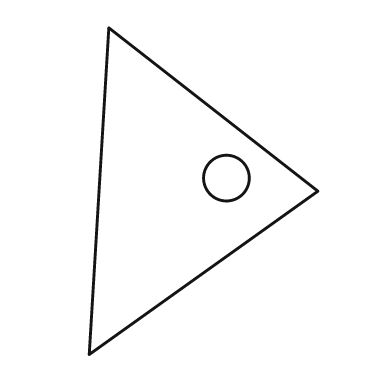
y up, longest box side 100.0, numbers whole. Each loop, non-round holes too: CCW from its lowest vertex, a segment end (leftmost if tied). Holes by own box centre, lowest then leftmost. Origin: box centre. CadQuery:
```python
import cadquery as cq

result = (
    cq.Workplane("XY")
    .moveTo(-35.0, -50.0)
    .lineTo(35.0, 0.0)
    .lineTo(-29.0, 50.0)
    .close()
    .moveTo(7.0, 4.0)
    .circle(7.0)
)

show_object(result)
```